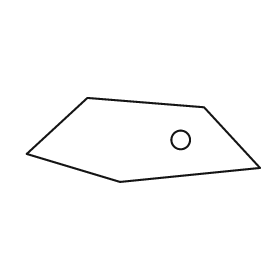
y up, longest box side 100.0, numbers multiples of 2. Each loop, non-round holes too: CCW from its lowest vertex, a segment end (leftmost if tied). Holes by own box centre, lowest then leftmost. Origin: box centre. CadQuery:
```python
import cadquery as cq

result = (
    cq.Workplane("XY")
    .moveTo(-10.0, -18.0)
    .lineTo(50.0, -12.0)
    .lineTo(26.0, 14.0)
    .lineTo(-24.0, 18.0)
    .lineTo(-50.0, -6.0)
    .close()
    .moveTo(16.0, 0.0)
    .circle(4.0)
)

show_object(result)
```